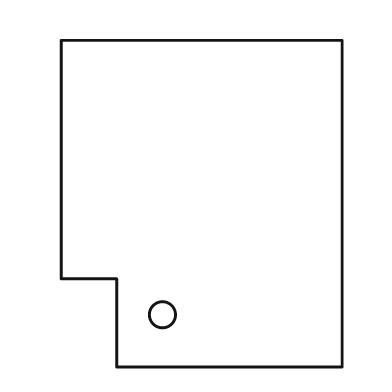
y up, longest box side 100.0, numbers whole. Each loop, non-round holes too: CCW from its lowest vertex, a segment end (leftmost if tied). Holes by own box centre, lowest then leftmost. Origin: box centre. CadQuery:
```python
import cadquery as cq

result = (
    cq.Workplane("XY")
    .moveTo(-26.0, -50.0)
    .lineTo(43.0, -50.0)
    .lineTo(43.0, 50.0)
    .lineTo(-43.0, 50.0)
    .lineTo(-43.0, -23.0)
    .lineTo(-26.0, -23.0)
    .close()
    .moveTo(-12.0, -34.0)
    .circle(4.0)
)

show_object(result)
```